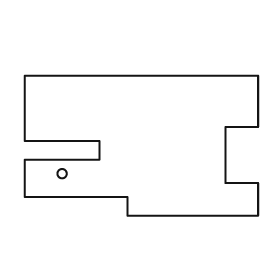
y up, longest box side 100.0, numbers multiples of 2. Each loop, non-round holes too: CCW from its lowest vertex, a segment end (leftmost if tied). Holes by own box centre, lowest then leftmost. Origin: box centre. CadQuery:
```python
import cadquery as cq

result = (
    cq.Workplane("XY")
    .moveTo(-6.0, -30.0)
    .lineTo(50.0, -30.0)
    .lineTo(50.0, -16.0)
    .lineTo(36.0, -16.0)
    .lineTo(36.0, 8.0)
    .lineTo(50.0, 8.0)
    .lineTo(50.0, 30.0)
    .lineTo(-50.0, 30.0)
    .lineTo(-50.0, 2.0)
    .lineTo(-18.0, 2.0)
    .lineTo(-18.0, -6.0)
    .lineTo(-50.0, -6.0)
    .lineTo(-50.0, -22.0)
    .lineTo(-6.0, -22.0)
    .close()
    .moveTo(-34.0, -12.0)
    .circle(2.0)
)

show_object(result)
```